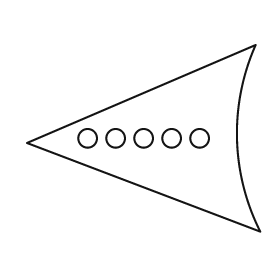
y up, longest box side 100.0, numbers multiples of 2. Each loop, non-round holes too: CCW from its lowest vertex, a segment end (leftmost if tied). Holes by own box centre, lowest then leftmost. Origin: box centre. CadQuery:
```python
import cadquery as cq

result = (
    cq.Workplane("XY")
    .moveTo(50.0, -40.0)
    .threePointArc((40.0, 0.0), (48.0, 40.0))
    .lineTo(-50.0, -2.0)
    .close()
    .moveTo(-24.0, 0.0)
    .circle(4.0)
    .moveTo(-12.0, 0.0)
    .circle(4.0)
    .moveTo(0.0, 0.0)
    .circle(4.0)
    .moveTo(12.0, 0.0)
    .circle(4.0)
    .moveTo(24.0, 0.0)
    .circle(4.0)
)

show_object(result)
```